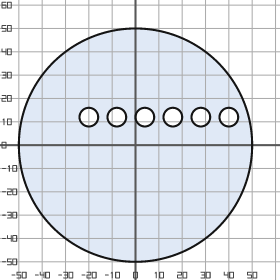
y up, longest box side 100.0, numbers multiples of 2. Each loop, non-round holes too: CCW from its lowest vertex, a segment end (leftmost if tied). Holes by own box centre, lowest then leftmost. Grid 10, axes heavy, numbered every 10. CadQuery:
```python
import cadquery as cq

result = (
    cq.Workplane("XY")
    .moveTo(0.0, 0.0)
    .circle(50.0)
    .moveTo(-20.0, 12.0)
    .circle(4.0)
    .moveTo(-8.0, 12.0)
    .circle(4.0)
    .moveTo(4.0, 12.0)
    .circle(4.0)
    .moveTo(16.0, 12.0)
    .circle(4.0)
    .moveTo(28.0, 12.0)
    .circle(4.0)
    .moveTo(40.0, 12.0)
    .circle(4.0)
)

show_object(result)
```